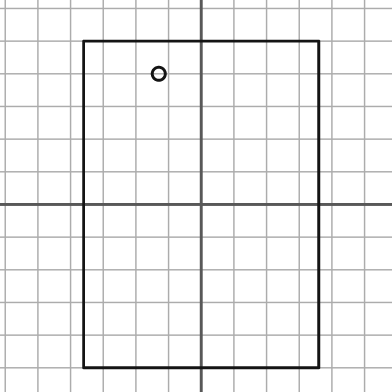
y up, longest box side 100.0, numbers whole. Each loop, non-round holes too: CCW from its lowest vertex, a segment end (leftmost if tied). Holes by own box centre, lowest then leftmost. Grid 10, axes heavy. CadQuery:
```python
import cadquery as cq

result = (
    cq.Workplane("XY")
    .moveTo(-36.0, -50.0)
    .lineTo(36.0, -50.0)
    .lineTo(36.0, 50.0)
    .lineTo(-36.0, 50.0)
    .close()
    .moveTo(-13.0, 40.0)
    .circle(2.0)
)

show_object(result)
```